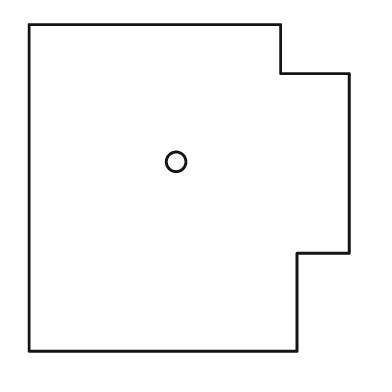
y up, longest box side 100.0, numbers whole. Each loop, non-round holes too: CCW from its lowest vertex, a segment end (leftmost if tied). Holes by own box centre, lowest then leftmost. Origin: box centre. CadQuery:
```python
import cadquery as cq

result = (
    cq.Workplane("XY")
    .moveTo(-49.0, -50.0)
    .lineTo(33.0, -50.0)
    .lineTo(33.0, -20.0)
    .lineTo(49.0, -20.0)
    .lineTo(49.0, 35.0)
    .lineTo(28.0, 35.0)
    .lineTo(28.0, 50.0)
    .lineTo(-49.0, 50.0)
    .close()
    .moveTo(-4.0, 8.0)
    .circle(3.0)
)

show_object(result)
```